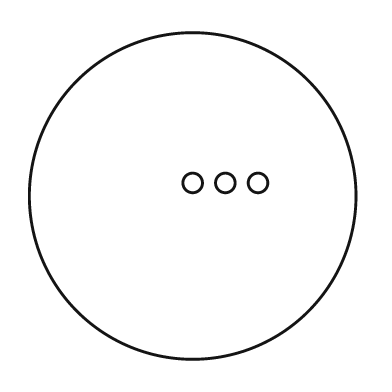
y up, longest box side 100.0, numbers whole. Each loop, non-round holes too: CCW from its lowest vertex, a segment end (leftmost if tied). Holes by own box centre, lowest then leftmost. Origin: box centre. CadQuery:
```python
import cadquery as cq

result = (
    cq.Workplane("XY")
    .moveTo(0.0, 0.0)
    .circle(50.0)
    .moveTo(0.0, 4.0)
    .circle(3.0)
    .moveTo(10.0, 4.0)
    .circle(3.0)
    .moveTo(20.0, 4.0)
    .circle(3.0)
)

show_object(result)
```